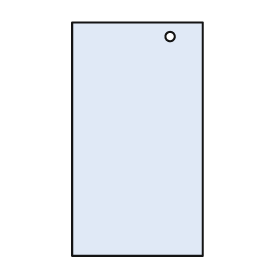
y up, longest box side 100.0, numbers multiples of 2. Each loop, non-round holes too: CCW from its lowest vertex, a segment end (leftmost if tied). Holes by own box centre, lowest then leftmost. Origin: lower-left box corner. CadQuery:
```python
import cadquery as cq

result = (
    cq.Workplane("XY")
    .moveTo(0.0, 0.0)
    .lineTo(56.0, 0.0)
    .lineTo(56.0, 100.0)
    .lineTo(0.0, 100.0)
    .close()
    .moveTo(42.0, 94.0)
    .circle(2.0)
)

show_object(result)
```